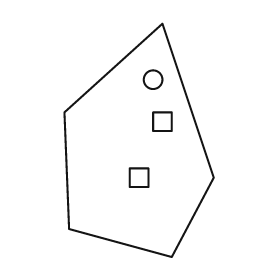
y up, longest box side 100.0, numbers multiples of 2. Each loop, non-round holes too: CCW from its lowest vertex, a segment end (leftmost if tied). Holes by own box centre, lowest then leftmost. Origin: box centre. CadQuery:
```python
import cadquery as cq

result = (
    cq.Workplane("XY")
    .moveTo(14.0, -50.0)
    .lineTo(32.0, -16.0)
    .lineTo(10.0, 50.0)
    .lineTo(-32.0, 12.0)
    .lineTo(-30.0, -38.0)
    .close()
    .moveTo(-4.0, -20.0)
    .lineTo(4.0, -20.0)
    .lineTo(4.0, -12.0)
    .lineTo(-4.0, -12.0)
    .close()
    .moveTo(6.0, 4.0)
    .lineTo(14.0, 4.0)
    .lineTo(14.0, 12.0)
    .lineTo(6.0, 12.0)
    .close()
    .moveTo(6.0, 26.0)
    .circle(4.0)
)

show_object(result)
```